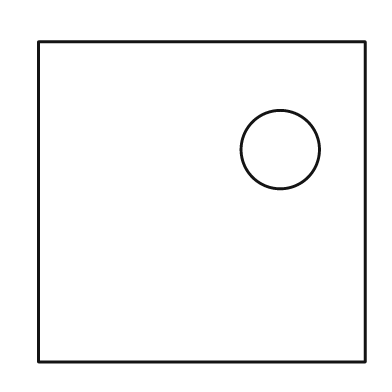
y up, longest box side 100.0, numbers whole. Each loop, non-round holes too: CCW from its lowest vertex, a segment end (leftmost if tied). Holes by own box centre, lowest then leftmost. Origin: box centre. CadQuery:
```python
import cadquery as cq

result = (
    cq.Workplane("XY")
    .moveTo(-50.0, -49.0)
    .lineTo(50.0, -49.0)
    .lineTo(50.0, 49.0)
    .lineTo(-50.0, 49.0)
    .close()
    .moveTo(24.0, 16.0)
    .circle(12.0)
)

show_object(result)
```